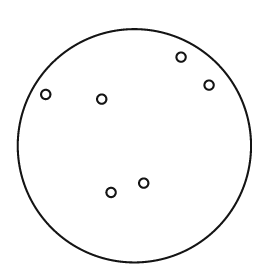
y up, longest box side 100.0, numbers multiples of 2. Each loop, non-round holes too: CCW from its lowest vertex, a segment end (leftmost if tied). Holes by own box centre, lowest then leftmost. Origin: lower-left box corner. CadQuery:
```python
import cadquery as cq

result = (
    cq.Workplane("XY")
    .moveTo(50.0, 50.0)
    .circle(50.0)
    .moveTo(40.0, 30.0)
    .circle(2.0)
    .moveTo(54.0, 34.0)
    .circle(2.0)
    .moveTo(36.0, 70.0)
    .circle(2.0)
    .moveTo(12.0, 72.0)
    .circle(2.0)
    .moveTo(82.0, 76.0)
    .circle(2.0)
    .moveTo(70.0, 88.0)
    .circle(2.0)
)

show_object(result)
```